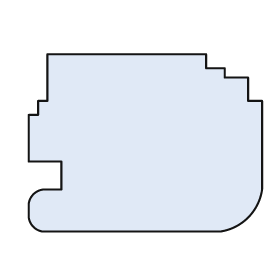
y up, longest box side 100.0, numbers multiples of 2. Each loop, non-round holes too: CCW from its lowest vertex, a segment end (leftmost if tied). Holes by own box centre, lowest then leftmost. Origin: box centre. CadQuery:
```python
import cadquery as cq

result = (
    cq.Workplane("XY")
    .moveTo(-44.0, -38.0)
    .lineTo(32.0, -38.0)
    .threePointArc((44.0, -32.0), (50.0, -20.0))
    .lineTo(50.0, 18.0)
    .lineTo(44.0, 18.0)
    .lineTo(44.0, 28.0)
    .lineTo(34.0, 28.0)
    .lineTo(34.0, 32.0)
    .lineTo(26.0, 32.0)
    .lineTo(26.0, 38.0)
    .lineTo(-42.0, 38.0)
    .lineTo(-42.0, 18.0)
    .lineTo(-46.0, 18.0)
    .lineTo(-46.0, 12.0)
    .lineTo(-50.0, 12.0)
    .lineTo(-50.0, -8.0)
    .lineTo(-36.0, -8.0)
    .lineTo(-36.0, -20.0)
    .lineTo(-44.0, -20.0)
    .threePointArc((-48.0, -22.0), (-50.0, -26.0))
    .lineTo(-50.0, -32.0)
    .threePointArc((-48.0, -36.0), (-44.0, -38.0))
    .close()
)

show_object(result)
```